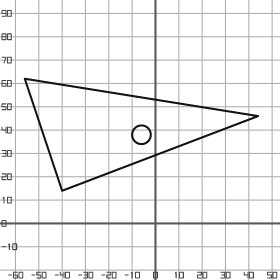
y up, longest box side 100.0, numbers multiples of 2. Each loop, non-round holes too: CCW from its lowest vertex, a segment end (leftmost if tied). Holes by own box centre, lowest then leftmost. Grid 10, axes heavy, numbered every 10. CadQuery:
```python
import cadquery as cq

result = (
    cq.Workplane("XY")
    .moveTo(-40.0, 14.0)
    .lineTo(44.0, 46.0)
    .lineTo(-56.0, 62.0)
    .close()
    .moveTo(-6.0, 38.0)
    .circle(4.0)
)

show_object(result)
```